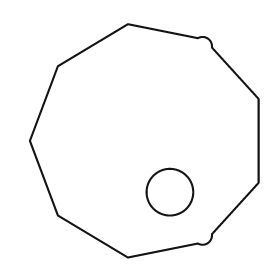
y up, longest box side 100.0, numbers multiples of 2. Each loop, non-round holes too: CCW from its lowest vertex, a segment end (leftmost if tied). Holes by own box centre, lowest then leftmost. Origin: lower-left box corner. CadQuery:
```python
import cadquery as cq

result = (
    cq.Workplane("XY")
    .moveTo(42.0, 0.0)
    .lineTo(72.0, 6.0)
    .threePointArc((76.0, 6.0), (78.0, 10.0))
    .lineTo(98.0, 32.0)
    .lineTo(98.0, 68.0)
    .lineTo(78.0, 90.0)
    .threePointArc((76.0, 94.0), (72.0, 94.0))
    .lineTo(42.0, 100.0)
    .lineTo(12.0, 82.0)
    .lineTo(0.0, 50.0)
    .lineTo(12.0, 18.0)
    .close()
    .moveTo(60.0, 28.0)
    .circle(10.0)
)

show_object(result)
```